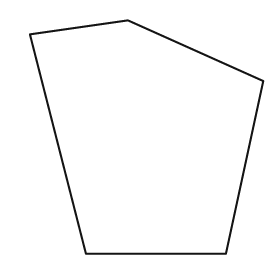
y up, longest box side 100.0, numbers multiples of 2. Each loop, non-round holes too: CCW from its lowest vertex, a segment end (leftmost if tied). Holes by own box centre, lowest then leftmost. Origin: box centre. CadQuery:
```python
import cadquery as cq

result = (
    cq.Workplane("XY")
    .moveTo(-26.0, -50.0)
    .lineTo(34.0, -50.0)
    .lineTo(50.0, 24.0)
    .lineTo(-8.0, 50.0)
    .lineTo(-50.0, 44.0)
    .close()
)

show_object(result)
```